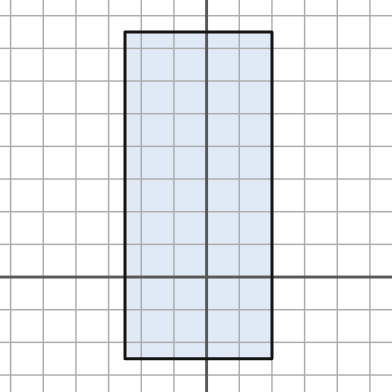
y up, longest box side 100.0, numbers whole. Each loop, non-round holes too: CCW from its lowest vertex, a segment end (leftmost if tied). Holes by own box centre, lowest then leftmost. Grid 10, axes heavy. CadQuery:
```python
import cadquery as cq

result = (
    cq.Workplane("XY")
    .moveTo(-25.0, -25.0)
    .lineTo(20.0, -25.0)
    .lineTo(20.0, 75.0)
    .lineTo(-25.0, 75.0)
    .close()
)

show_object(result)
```